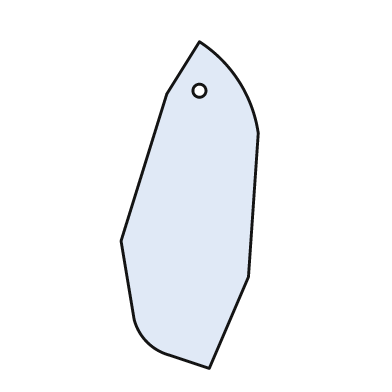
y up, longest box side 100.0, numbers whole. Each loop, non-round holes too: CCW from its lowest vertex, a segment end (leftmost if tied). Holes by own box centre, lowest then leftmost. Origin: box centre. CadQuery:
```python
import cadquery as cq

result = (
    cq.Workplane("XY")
    .moveTo(6.0, -50.0)
    .lineTo(18.0, -22.0)
    .lineTo(21.0, 22.0)
    .threePointArc((15.0, 38.0), (3.0, 50.0))
    .lineTo(-7.0, 34.0)
    .lineTo(-21.0, -11.0)
    .lineTo(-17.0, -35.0)
    .threePointArc((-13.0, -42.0), (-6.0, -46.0))
    .close()
    .moveTo(3.0, 35.0)
    .circle(2.0)
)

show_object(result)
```